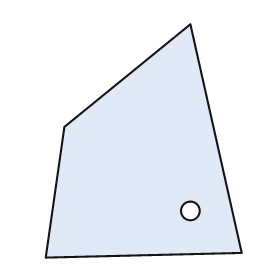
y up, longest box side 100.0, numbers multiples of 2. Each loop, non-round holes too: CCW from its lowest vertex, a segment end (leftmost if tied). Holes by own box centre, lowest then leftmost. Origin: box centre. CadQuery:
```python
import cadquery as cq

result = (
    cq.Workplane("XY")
    .moveTo(-42.0, -50.0)
    .lineTo(42.0, -48.0)
    .lineTo(20.0, 50.0)
    .lineTo(-34.0, 6.0)
    .close()
    .moveTo(20.0, -30.0)
    .circle(4.0)
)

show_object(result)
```